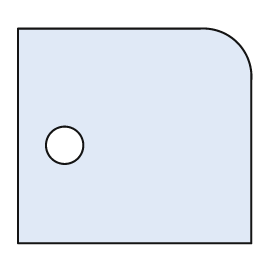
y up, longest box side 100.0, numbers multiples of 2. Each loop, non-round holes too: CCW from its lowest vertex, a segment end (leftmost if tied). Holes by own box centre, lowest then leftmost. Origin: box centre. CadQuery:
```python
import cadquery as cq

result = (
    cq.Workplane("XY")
    .moveTo(-50.0, -46.0)
    .lineTo(50.0, -46.0)
    .lineTo(50.0, 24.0)
    .threePointArc((44.0, 40.0), (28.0, 46.0))
    .lineTo(-50.0, 46.0)
    .close()
    .moveTo(-30.0, -4.0)
    .circle(8.0)
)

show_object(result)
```